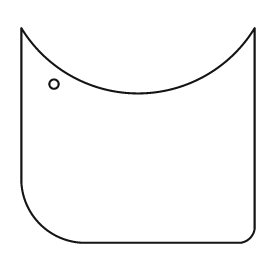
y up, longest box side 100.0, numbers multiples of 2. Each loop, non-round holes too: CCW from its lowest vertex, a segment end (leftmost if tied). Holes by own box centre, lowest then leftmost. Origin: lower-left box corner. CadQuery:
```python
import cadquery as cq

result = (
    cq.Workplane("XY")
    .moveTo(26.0, 0.0)
    .lineTo(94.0, 0.0)
    .threePointArc((98.0, 2.0), (100.0, 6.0))
    .lineTo(100.0, 92.0)
    .threePointArc((50.0, 64.0), (0.0, 92.0))
    .lineTo(0.0, 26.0)
    .threePointArc((8.0, 8.0), (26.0, 0.0))
    .close()
    .moveTo(14.0, 68.0)
    .circle(2.0)
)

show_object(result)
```